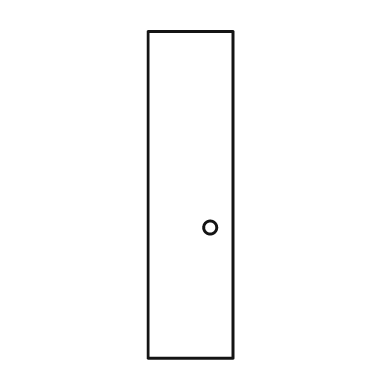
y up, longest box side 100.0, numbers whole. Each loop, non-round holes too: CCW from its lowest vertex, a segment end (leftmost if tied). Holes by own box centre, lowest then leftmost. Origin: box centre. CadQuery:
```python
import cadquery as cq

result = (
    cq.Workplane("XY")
    .moveTo(-13.0, -50.0)
    .lineTo(13.0, -50.0)
    .lineTo(13.0, 50.0)
    .lineTo(-13.0, 50.0)
    .close()
    .moveTo(6.0, -10.0)
    .circle(2.0)
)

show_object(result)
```